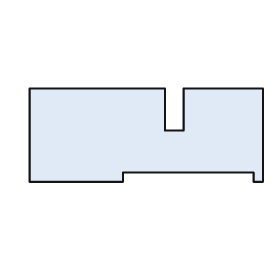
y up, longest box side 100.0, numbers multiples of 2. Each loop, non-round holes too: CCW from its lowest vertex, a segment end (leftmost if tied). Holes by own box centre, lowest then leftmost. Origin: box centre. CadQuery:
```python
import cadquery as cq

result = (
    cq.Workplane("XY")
    .moveTo(-50.0, -20.0)
    .lineTo(-10.0, -20.0)
    .lineTo(-10.0, -16.0)
    .lineTo(46.0, -16.0)
    .lineTo(46.0, -20.0)
    .lineTo(50.0, -20.0)
    .lineTo(50.0, 20.0)
    .lineTo(16.0, 20.0)
    .lineTo(16.0, 2.0)
    .lineTo(8.0, 2.0)
    .lineTo(8.0, 20.0)
    .lineTo(-50.0, 20.0)
    .close()
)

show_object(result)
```